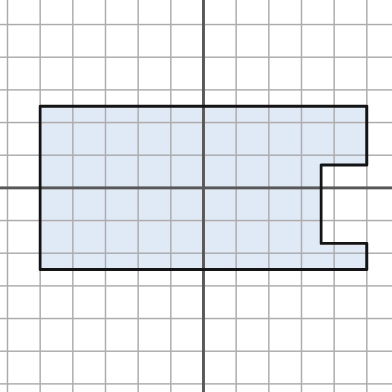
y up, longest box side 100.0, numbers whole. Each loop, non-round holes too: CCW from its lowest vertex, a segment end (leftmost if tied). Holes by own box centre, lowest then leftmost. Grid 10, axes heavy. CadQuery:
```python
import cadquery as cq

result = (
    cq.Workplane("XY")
    .moveTo(-50.0, -25.0)
    .lineTo(50.0, -25.0)
    .lineTo(50.0, -17.0)
    .lineTo(36.0, -17.0)
    .lineTo(36.0, 7.0)
    .lineTo(50.0, 7.0)
    .lineTo(50.0, 25.0)
    .lineTo(-50.0, 25.0)
    .close()
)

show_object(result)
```